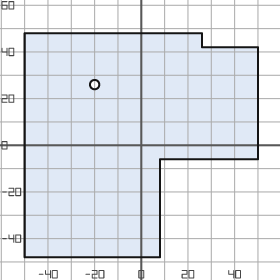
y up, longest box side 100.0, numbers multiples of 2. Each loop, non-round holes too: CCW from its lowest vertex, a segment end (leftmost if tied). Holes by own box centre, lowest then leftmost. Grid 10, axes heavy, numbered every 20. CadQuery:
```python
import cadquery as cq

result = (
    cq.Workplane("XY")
    .moveTo(-50.0, -48.0)
    .lineTo(8.0, -48.0)
    .lineTo(8.0, -6.0)
    .lineTo(50.0, -6.0)
    .lineTo(50.0, 42.0)
    .lineTo(26.0, 42.0)
    .lineTo(26.0, 48.0)
    .lineTo(-50.0, 48.0)
    .close()
    .moveTo(-20.0, 26.0)
    .circle(2.0)
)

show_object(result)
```